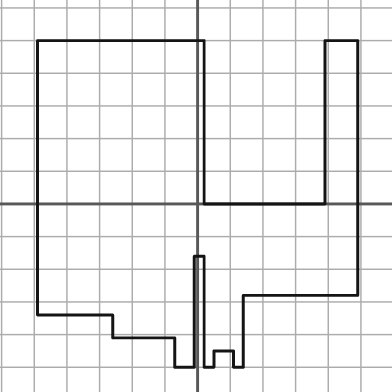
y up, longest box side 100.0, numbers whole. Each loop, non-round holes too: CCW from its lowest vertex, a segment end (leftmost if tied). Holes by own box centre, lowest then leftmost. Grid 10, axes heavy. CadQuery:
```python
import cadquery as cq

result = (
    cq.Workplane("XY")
    .moveTo(-7.0, -50.0)
    .lineTo(-1.0, -50.0)
    .lineTo(-1.0, -16.0)
    .lineTo(2.0, -16.0)
    .lineTo(2.0, -50.0)
    .lineTo(5.0, -50.0)
    .lineTo(5.0, -45.0)
    .lineTo(11.0, -45.0)
    .lineTo(11.0, -50.0)
    .lineTo(14.0, -50.0)
    .lineTo(14.0, -28.0)
    .lineTo(49.0, -28.0)
    .lineTo(49.0, 50.0)
    .lineTo(39.0, 50.0)
    .lineTo(39.0, 0.0)
    .lineTo(2.0, 0.0)
    .lineTo(2.0, 50.0)
    .lineTo(-49.0, 50.0)
    .lineTo(-49.0, -34.0)
    .lineTo(-26.0, -34.0)
    .lineTo(-26.0, -41.0)
    .lineTo(-7.0, -41.0)
    .close()
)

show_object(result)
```